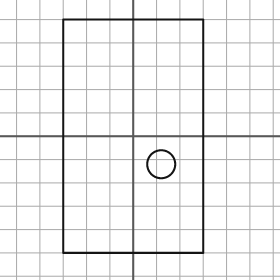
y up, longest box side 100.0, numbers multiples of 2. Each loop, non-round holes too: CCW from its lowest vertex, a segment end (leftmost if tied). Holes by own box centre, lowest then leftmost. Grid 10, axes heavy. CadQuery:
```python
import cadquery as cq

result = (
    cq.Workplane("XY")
    .moveTo(-30.0, -50.0)
    .lineTo(30.0, -50.0)
    .lineTo(30.0, 50.0)
    .lineTo(-30.0, 50.0)
    .close()
    .moveTo(12.0, -12.0)
    .circle(6.0)
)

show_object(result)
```